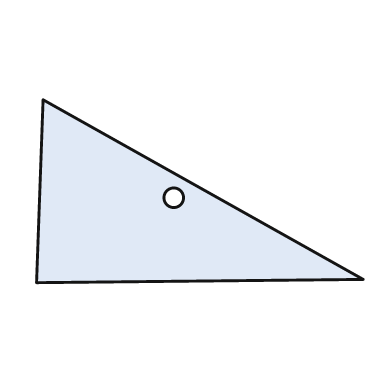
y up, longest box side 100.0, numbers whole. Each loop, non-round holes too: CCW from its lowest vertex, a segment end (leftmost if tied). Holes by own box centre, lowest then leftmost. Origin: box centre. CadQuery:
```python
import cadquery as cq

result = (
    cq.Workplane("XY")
    .moveTo(-50.0, -28.0)
    .lineTo(50.0, -27.0)
    .lineTo(-48.0, 28.0)
    .close()
    .moveTo(-8.0, -2.0)
    .circle(3.0)
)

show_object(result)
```